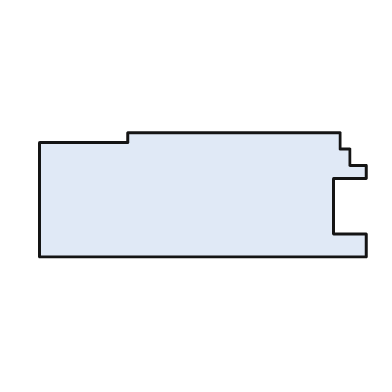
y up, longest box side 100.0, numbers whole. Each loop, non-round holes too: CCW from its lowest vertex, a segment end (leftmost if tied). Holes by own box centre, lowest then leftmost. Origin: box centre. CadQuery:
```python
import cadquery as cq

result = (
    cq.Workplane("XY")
    .moveTo(-50.0, -19.0)
    .lineTo(50.0, -19.0)
    .lineTo(50.0, -12.0)
    .lineTo(40.0, -12.0)
    .lineTo(40.0, 5.0)
    .lineTo(50.0, 5.0)
    .lineTo(50.0, 9.0)
    .lineTo(45.0, 9.0)
    .lineTo(45.0, 14.0)
    .lineTo(42.0, 14.0)
    .lineTo(42.0, 19.0)
    .lineTo(-23.0, 19.0)
    .lineTo(-23.0, 16.0)
    .lineTo(-50.0, 16.0)
    .close()
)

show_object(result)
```